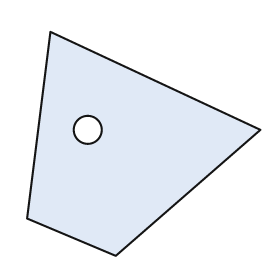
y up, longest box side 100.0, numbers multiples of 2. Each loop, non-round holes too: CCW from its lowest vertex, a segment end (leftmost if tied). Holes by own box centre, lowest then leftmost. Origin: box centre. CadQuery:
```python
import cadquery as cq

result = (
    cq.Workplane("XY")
    .moveTo(-12.0, -48.0)
    .lineTo(50.0, 6.0)
    .lineTo(-40.0, 48.0)
    .lineTo(-50.0, -32.0)
    .close()
    .moveTo(-24.0, 6.0)
    .circle(6.0)
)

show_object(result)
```